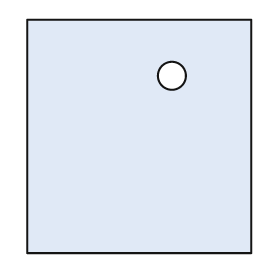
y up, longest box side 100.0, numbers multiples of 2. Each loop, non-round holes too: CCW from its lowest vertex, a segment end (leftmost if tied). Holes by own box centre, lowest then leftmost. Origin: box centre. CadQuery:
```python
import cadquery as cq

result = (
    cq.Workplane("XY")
    .moveTo(-48.0, -50.0)
    .lineTo(48.0, -50.0)
    .lineTo(48.0, 50.0)
    .lineTo(-48.0, 50.0)
    .close()
    .moveTo(14.0, 26.0)
    .circle(6.0)
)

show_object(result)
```